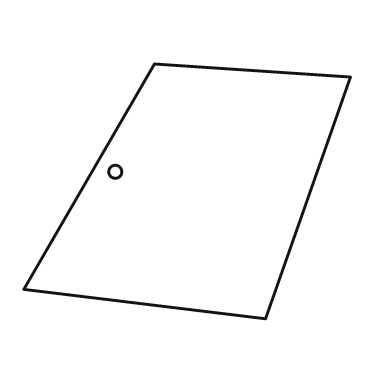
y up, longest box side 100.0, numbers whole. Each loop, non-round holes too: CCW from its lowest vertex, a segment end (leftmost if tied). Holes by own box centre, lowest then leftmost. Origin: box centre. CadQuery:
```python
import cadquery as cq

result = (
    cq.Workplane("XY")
    .moveTo(24.0, -39.0)
    .lineTo(50.0, 35.0)
    .lineTo(-10.0, 39.0)
    .lineTo(-50.0, -30.0)
    .close()
    .moveTo(-22.0, 6.0)
    .circle(2.0)
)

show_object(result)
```